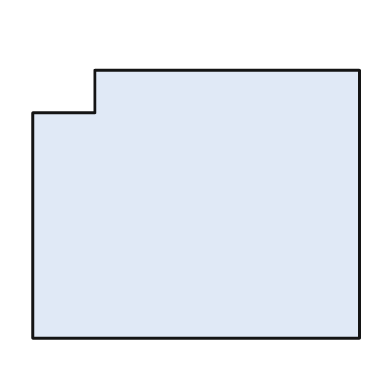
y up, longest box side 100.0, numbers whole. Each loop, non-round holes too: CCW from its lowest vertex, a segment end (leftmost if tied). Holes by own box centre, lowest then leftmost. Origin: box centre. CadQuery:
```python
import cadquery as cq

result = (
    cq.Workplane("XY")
    .moveTo(-50.0, -41.0)
    .lineTo(50.0, -41.0)
    .lineTo(50.0, 41.0)
    .lineTo(-31.0, 41.0)
    .lineTo(-31.0, 28.0)
    .lineTo(-50.0, 28.0)
    .close()
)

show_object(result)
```